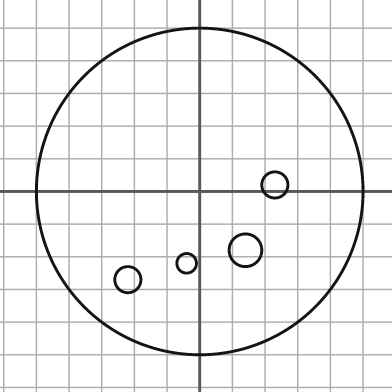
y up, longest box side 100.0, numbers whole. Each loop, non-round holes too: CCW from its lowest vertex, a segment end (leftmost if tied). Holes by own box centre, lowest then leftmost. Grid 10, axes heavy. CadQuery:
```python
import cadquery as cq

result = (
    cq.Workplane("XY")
    .moveTo(0.0, 0.0)
    .circle(50.0)
    .moveTo(-22.0, -27.0)
    .circle(4.0)
    .moveTo(-4.0, -22.0)
    .circle(3.0)
    .moveTo(14.0, -18.0)
    .circle(5.0)
    .moveTo(23.0, 2.0)
    .circle(4.0)
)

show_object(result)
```